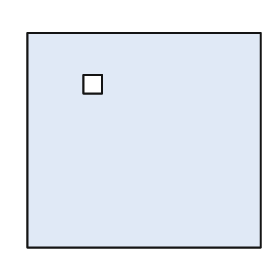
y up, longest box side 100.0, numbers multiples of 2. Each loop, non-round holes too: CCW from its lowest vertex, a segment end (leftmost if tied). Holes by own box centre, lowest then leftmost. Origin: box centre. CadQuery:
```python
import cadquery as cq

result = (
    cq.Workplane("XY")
    .moveTo(-50.0, -46.0)
    .lineTo(50.0, -46.0)
    .lineTo(50.0, 46.0)
    .lineTo(-50.0, 46.0)
    .close()
    .moveTo(-26.0, 20.0)
    .lineTo(-18.0, 20.0)
    .lineTo(-18.0, 28.0)
    .lineTo(-26.0, 28.0)
    .close()
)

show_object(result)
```